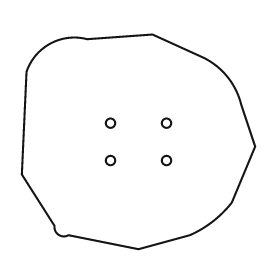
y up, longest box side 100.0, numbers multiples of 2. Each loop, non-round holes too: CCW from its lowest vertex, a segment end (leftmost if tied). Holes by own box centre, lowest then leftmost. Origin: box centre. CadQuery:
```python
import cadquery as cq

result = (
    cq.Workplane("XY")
    .moveTo(0.0, -46.0)
    .lineTo(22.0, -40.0)
    .threePointArc((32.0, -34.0), (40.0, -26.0))
    .lineTo(50.0, -2.0)
    .lineTo(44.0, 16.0)
    .threePointArc((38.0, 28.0), (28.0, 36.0))
    .lineTo(6.0, 46.0)
    .lineTo(-22.0, 44.0)
    .threePointArc((-38.0, 42.0), (-48.0, 30.0))
    .lineTo(-50.0, -14.0)
    .lineTo(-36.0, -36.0)
    .threePointArc((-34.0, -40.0), (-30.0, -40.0))
    .close()
    .moveTo(-12.0, -8.0)
    .circle(2.0)
    .moveTo(12.0, -8.0)
    .circle(2.0)
    .moveTo(-12.0, 8.0)
    .circle(2.0)
    .moveTo(12.0, 8.0)
    .circle(2.0)
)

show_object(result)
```